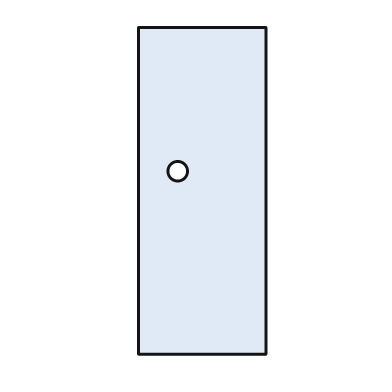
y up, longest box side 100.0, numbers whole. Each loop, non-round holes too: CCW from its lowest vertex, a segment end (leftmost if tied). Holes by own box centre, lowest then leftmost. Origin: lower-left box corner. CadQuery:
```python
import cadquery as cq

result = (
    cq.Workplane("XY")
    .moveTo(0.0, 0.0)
    .lineTo(39.0, 0.0)
    .lineTo(39.0, 100.0)
    .lineTo(0.0, 100.0)
    .close()
    .moveTo(12.0, 56.0)
    .circle(3.0)
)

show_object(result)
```